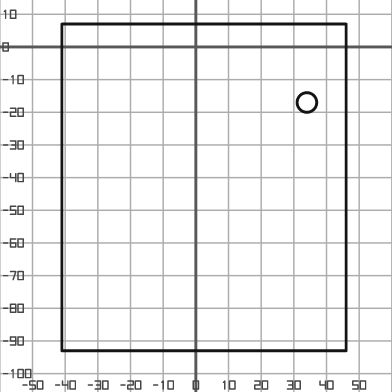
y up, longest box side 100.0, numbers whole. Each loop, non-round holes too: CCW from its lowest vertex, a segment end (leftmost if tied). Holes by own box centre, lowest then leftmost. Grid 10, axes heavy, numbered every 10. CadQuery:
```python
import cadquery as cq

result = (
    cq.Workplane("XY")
    .moveTo(-41.0, -93.0)
    .lineTo(46.0, -93.0)
    .lineTo(46.0, 7.0)
    .lineTo(-41.0, 7.0)
    .close()
    .moveTo(34.0, -17.0)
    .circle(3.0)
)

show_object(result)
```